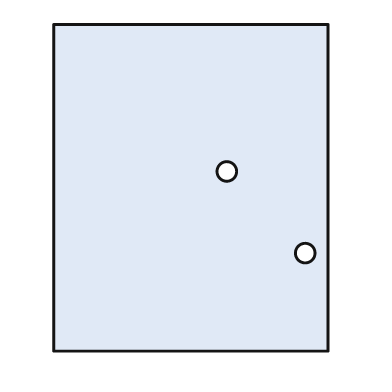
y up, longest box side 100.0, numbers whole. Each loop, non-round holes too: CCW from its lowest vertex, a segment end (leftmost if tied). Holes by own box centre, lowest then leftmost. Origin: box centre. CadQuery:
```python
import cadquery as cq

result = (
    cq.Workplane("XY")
    .moveTo(-42.0, -50.0)
    .lineTo(42.0, -50.0)
    .lineTo(42.0, 50.0)
    .lineTo(-42.0, 50.0)
    .close()
    .moveTo(35.0, -20.0)
    .circle(3.0)
    .moveTo(11.0, 5.0)
    .circle(3.0)
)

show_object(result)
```